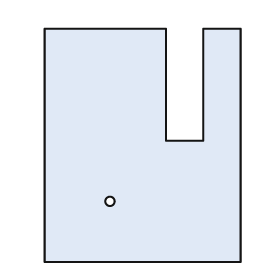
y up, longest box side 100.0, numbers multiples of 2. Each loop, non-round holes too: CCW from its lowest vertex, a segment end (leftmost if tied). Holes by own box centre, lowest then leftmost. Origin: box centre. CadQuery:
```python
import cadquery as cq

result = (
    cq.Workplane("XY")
    .moveTo(-42.0, -50.0)
    .lineTo(42.0, -50.0)
    .lineTo(42.0, 50.0)
    .lineTo(26.0, 50.0)
    .lineTo(26.0, 2.0)
    .lineTo(10.0, 2.0)
    .lineTo(10.0, 50.0)
    .lineTo(-42.0, 50.0)
    .close()
    .moveTo(-14.0, -24.0)
    .circle(2.0)
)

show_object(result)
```